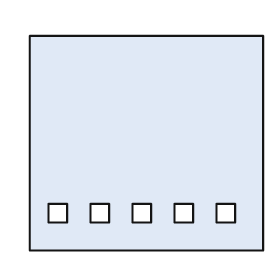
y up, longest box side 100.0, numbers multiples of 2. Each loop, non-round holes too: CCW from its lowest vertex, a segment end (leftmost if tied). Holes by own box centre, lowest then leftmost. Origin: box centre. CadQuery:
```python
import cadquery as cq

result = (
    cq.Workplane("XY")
    .moveTo(-50.0, -46.0)
    .lineTo(50.0, -46.0)
    .lineTo(50.0, 46.0)
    .lineTo(-50.0, 46.0)
    .close()
    .moveTo(-42.0, -34.0)
    .lineTo(-34.0, -34.0)
    .lineTo(-34.0, -26.0)
    .lineTo(-42.0, -26.0)
    .close()
    .moveTo(-24.0, -34.0)
    .lineTo(-16.0, -34.0)
    .lineTo(-16.0, -26.0)
    .lineTo(-24.0, -26.0)
    .close()
    .moveTo(-6.0, -34.0)
    .lineTo(2.0, -34.0)
    .lineTo(2.0, -26.0)
    .lineTo(-6.0, -26.0)
    .close()
    .moveTo(12.0, -34.0)
    .lineTo(20.0, -34.0)
    .lineTo(20.0, -26.0)
    .lineTo(12.0, -26.0)
    .close()
    .moveTo(30.0, -34.0)
    .lineTo(38.0, -34.0)
    .lineTo(38.0, -26.0)
    .lineTo(30.0, -26.0)
    .close()
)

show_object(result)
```